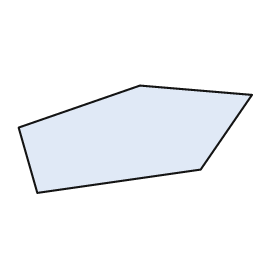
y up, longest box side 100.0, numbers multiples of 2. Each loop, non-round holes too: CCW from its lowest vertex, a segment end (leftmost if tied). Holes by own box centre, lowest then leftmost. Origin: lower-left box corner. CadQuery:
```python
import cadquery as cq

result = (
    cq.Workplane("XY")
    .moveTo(8.0, 0.0)
    .lineTo(78.0, 10.0)
    .lineTo(100.0, 42.0)
    .lineTo(52.0, 46.0)
    .lineTo(0.0, 28.0)
    .close()
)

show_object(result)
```